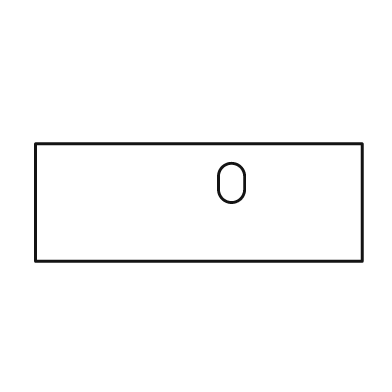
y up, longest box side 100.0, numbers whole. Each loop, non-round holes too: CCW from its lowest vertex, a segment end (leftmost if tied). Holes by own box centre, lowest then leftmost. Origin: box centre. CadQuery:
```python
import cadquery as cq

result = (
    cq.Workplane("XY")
    .moveTo(-50.0, -18.0)
    .lineTo(50.0, -18.0)
    .lineTo(50.0, 18.0)
    .lineTo(-50.0, 18.0)
    .close()
    .moveTo(6.0, 4.0)
    .threePointArc((10.0, 0.0), (14.0, 4.0))
    .lineTo(14.0, 8.0)
    .threePointArc((10.0, 12.0), (6.0, 8.0))
    .close()
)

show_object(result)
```